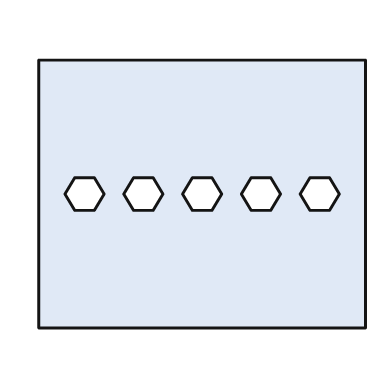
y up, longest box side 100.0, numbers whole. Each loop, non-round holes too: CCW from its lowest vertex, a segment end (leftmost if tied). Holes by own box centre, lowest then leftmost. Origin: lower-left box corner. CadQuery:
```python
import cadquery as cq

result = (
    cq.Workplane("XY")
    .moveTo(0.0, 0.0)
    .lineTo(100.0, 0.0)
    .lineTo(100.0, 82.0)
    .lineTo(0.0, 82.0)
    .close()
    .moveTo(11.0, 36.0)
    .lineTo(17.0, 36.0)
    .lineTo(20.0, 41.0)
    .lineTo(17.0, 46.0)
    .lineTo(11.0, 46.0)
    .lineTo(8.0, 41.0)
    .close()
    .moveTo(29.0, 36.0)
    .lineTo(35.0, 36.0)
    .lineTo(38.0, 41.0)
    .lineTo(35.0, 46.0)
    .lineTo(29.0, 46.0)
    .lineTo(26.0, 41.0)
    .close()
    .moveTo(47.0, 36.0)
    .lineTo(53.0, 36.0)
    .lineTo(56.0, 41.0)
    .lineTo(53.0, 46.0)
    .lineTo(47.0, 46.0)
    .lineTo(44.0, 41.0)
    .close()
    .moveTo(65.0, 36.0)
    .lineTo(71.0, 36.0)
    .lineTo(74.0, 41.0)
    .lineTo(71.0, 46.0)
    .lineTo(65.0, 46.0)
    .lineTo(62.0, 41.0)
    .close()
    .moveTo(83.0, 36.0)
    .lineTo(89.0, 36.0)
    .lineTo(92.0, 41.0)
    .lineTo(89.0, 46.0)
    .lineTo(83.0, 46.0)
    .lineTo(80.0, 41.0)
    .close()
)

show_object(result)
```